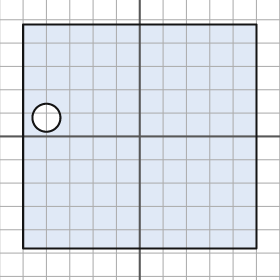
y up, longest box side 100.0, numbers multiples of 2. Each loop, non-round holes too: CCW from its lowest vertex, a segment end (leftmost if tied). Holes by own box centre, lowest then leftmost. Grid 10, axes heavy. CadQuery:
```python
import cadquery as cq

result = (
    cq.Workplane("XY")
    .moveTo(-50.0, -48.0)
    .lineTo(50.0, -48.0)
    .lineTo(50.0, 48.0)
    .lineTo(-50.0, 48.0)
    .close()
    .moveTo(-40.0, 8.0)
    .circle(6.0)
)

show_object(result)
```